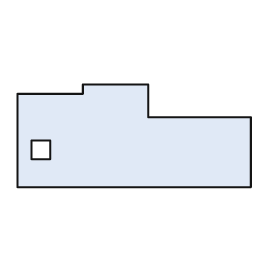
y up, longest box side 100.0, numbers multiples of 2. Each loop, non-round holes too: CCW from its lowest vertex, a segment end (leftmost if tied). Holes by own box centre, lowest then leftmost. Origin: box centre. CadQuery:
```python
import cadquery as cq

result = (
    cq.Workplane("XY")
    .moveTo(-50.0, -22.0)
    .lineTo(50.0, -22.0)
    .lineTo(50.0, 8.0)
    .lineTo(6.0, 8.0)
    .lineTo(6.0, 22.0)
    .lineTo(-22.0, 22.0)
    .lineTo(-22.0, 18.0)
    .lineTo(-50.0, 18.0)
    .close()
    .moveTo(-44.0, -10.0)
    .lineTo(-36.0, -10.0)
    .lineTo(-36.0, -2.0)
    .lineTo(-44.0, -2.0)
    .close()
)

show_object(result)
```